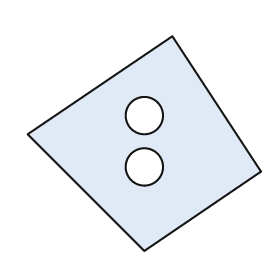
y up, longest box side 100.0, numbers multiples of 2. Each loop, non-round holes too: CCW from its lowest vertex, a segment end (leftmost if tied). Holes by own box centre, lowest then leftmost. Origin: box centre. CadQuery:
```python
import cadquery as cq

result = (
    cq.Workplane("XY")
    .moveTo(0.0, -46.0)
    .lineTo(50.0, -12.0)
    .lineTo(12.0, 46.0)
    .lineTo(-50.0, 4.0)
    .close()
    .moveTo(0.0, -10.0)
    .circle(8.0)
    .moveTo(0.0, 12.0)
    .circle(8.0)
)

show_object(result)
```